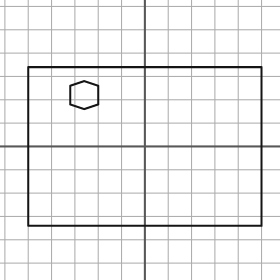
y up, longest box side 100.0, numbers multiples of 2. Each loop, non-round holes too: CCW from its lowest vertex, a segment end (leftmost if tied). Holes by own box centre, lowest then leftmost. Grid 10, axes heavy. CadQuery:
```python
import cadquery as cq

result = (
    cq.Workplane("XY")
    .moveTo(-50.0, -34.0)
    .lineTo(50.0, -34.0)
    .lineTo(50.0, 34.0)
    .lineTo(-50.0, 34.0)
    .close()
    .moveTo(-26.0, 16.0)
    .lineTo(-20.0, 18.0)
    .lineTo(-20.0, 26.0)
    .lineTo(-26.0, 28.0)
    .lineTo(-32.0, 26.0)
    .lineTo(-32.0, 18.0)
    .close()
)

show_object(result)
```